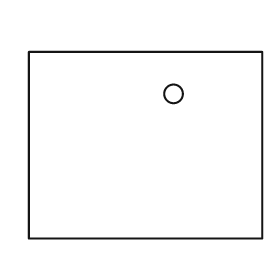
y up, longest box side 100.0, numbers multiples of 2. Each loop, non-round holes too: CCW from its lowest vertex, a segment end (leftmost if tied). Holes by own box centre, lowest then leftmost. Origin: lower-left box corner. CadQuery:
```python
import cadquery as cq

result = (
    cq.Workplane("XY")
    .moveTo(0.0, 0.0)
    .lineTo(100.0, 0.0)
    .lineTo(100.0, 80.0)
    .lineTo(0.0, 80.0)
    .close()
    .moveTo(62.0, 62.0)
    .circle(4.0)
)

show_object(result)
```